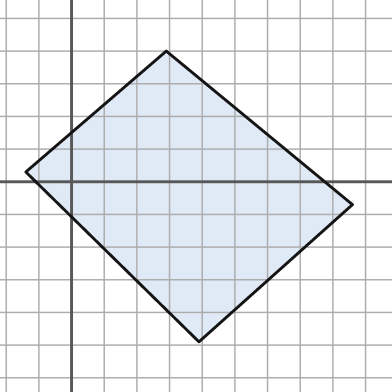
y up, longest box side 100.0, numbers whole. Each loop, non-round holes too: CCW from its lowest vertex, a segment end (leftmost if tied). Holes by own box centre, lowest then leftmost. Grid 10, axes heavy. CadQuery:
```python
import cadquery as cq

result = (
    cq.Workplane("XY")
    .moveTo(39.0, -49.0)
    .lineTo(86.0, -7.0)
    .lineTo(29.0, 40.0)
    .lineTo(-14.0, 3.0)
    .close()
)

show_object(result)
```